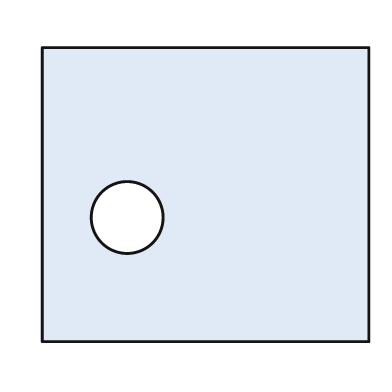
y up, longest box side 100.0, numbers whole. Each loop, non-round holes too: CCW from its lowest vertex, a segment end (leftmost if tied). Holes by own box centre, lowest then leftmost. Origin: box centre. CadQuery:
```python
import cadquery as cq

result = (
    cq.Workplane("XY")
    .moveTo(-50.0, -45.0)
    .lineTo(50.0, -45.0)
    .lineTo(50.0, 45.0)
    .lineTo(-50.0, 45.0)
    .close()
    .moveTo(-24.0, -7.0)
    .circle(11.0)
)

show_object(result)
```